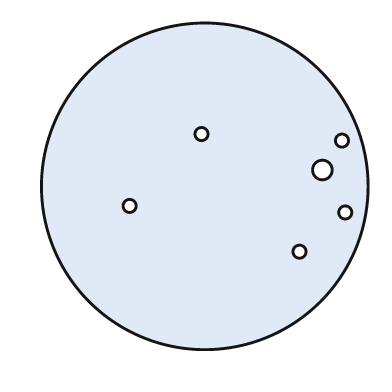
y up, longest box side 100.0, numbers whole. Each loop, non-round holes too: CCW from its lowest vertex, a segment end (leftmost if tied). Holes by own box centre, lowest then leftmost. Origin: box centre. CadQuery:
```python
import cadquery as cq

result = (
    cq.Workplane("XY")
    .moveTo(0.0, 0.0)
    .circle(50.0)
    .moveTo(29.0, -20.0)
    .circle(2.0)
    .moveTo(43.0, -8.0)
    .circle(2.0)
    .moveTo(-23.0, -6.0)
    .circle(2.0)
    .moveTo(36.0, 5.0)
    .circle(3.0)
    .moveTo(42.0, 14.0)
    .circle(2.0)
    .moveTo(-1.0, 16.0)
    .circle(2.0)
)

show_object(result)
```